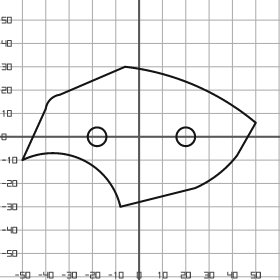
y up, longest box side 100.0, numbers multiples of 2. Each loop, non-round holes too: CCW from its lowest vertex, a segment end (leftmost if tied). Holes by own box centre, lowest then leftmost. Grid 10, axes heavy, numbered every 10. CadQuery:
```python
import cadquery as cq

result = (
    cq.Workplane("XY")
    .moveTo(-8.0, -30.0)
    .lineTo(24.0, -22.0)
    .threePointArc((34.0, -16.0), (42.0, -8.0))
    .lineTo(50.0, 6.0)
    .threePointArc((24.0, 22.0), (-6.0, 30.0))
    .lineTo(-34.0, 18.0)
    .threePointArc((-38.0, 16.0), (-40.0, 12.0))
    .lineTo(-50.0, -10.0)
    .threePointArc((-24.0, -10.0), (-8.0, -30.0))
    .close()
    .moveTo(-18.0, 0.0)
    .circle(4.0)
    .moveTo(20.0, 0.0)
    .circle(4.0)
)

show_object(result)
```